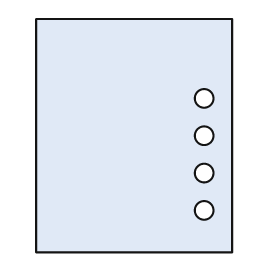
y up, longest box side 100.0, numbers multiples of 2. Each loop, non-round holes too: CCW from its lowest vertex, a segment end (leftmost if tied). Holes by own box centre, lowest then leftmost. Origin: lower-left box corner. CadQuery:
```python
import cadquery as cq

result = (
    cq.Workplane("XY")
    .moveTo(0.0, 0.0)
    .lineTo(84.0, 0.0)
    .lineTo(84.0, 100.0)
    .lineTo(0.0, 100.0)
    .close()
    .moveTo(72.0, 18.0)
    .circle(4.0)
    .moveTo(72.0, 34.0)
    .circle(4.0)
    .moveTo(72.0, 50.0)
    .circle(4.0)
    .moveTo(72.0, 66.0)
    .circle(4.0)
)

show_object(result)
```